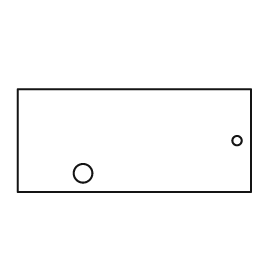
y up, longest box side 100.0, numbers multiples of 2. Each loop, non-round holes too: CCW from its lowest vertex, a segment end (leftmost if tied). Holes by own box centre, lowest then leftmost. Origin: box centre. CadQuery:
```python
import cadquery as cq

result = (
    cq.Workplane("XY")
    .moveTo(-50.0, -22.0)
    .lineTo(50.0, -22.0)
    .lineTo(50.0, 22.0)
    .lineTo(-50.0, 22.0)
    .close()
    .moveTo(-22.0, -14.0)
    .circle(4.0)
    .moveTo(44.0, 0.0)
    .circle(2.0)
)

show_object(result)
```